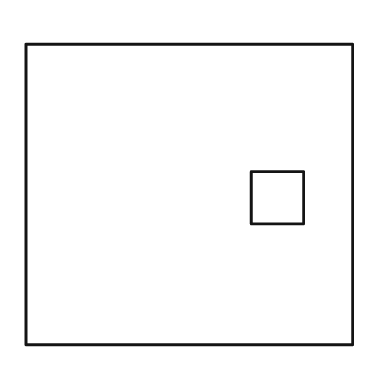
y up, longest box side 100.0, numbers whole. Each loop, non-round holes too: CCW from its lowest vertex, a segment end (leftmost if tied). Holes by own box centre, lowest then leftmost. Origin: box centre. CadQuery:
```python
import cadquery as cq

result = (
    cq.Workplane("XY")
    .moveTo(-50.0, -46.0)
    .lineTo(50.0, -46.0)
    .lineTo(50.0, 46.0)
    .lineTo(-50.0, 46.0)
    .close()
    .moveTo(19.0, -9.0)
    .lineTo(35.0, -9.0)
    .lineTo(35.0, 7.0)
    .lineTo(19.0, 7.0)
    .close()
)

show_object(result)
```